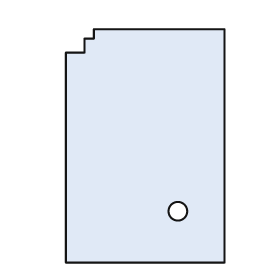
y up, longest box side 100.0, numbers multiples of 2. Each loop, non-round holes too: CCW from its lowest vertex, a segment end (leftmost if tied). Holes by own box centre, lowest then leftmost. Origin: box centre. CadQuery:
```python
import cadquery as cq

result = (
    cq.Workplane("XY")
    .moveTo(-34.0, -50.0)
    .lineTo(34.0, -50.0)
    .lineTo(34.0, 50.0)
    .lineTo(-22.0, 50.0)
    .lineTo(-22.0, 46.0)
    .lineTo(-26.0, 46.0)
    .lineTo(-26.0, 40.0)
    .lineTo(-34.0, 40.0)
    .close()
    .moveTo(14.0, -28.0)
    .circle(4.0)
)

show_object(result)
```